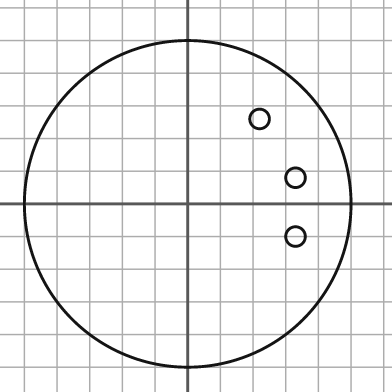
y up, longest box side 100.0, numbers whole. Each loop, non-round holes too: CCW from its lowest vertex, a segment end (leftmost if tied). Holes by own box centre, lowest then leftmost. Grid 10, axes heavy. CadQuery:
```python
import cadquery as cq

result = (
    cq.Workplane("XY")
    .moveTo(0.0, 0.0)
    .circle(50.0)
    .moveTo(33.0, -10.0)
    .circle(3.0)
    .moveTo(33.0, 8.0)
    .circle(3.0)
    .moveTo(22.0, 26.0)
    .circle(3.0)
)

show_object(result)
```